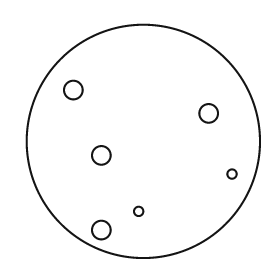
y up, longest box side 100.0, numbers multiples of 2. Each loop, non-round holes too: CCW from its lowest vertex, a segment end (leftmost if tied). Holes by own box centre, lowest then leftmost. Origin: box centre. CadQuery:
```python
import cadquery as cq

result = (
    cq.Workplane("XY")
    .moveTo(0.0, 0.0)
    .circle(50.0)
    .moveTo(-18.0, -38.0)
    .circle(4.0)
    .moveTo(-2.0, -30.0)
    .circle(2.0)
    .moveTo(38.0, -14.0)
    .circle(2.0)
    .moveTo(-18.0, -6.0)
    .circle(4.0)
    .moveTo(28.0, 12.0)
    .circle(4.0)
    .moveTo(-30.0, 22.0)
    .circle(4.0)
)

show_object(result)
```